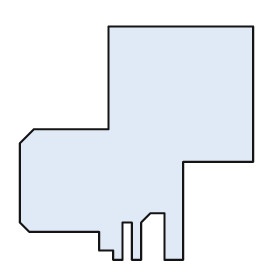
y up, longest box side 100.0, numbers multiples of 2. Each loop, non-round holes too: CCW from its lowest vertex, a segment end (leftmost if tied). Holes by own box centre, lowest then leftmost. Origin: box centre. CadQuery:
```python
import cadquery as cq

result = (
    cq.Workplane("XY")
    .moveTo(-10.0, -50.0)
    .lineTo(-6.0, -50.0)
    .lineTo(-6.0, -34.0)
    .lineTo(-2.0, -34.0)
    .lineTo(-2.0, -50.0)
    .lineTo(2.0, -50.0)
    .lineTo(2.0, -34.0)
    .lineTo(6.0, -30.0)
    .lineTo(12.0, -30.0)
    .lineTo(12.0, -50.0)
    .lineTo(20.0, -50.0)
    .lineTo(20.0, -8.0)
    .lineTo(50.0, -8.0)
    .lineTo(50.0, 50.0)
    .lineTo(-12.0, 50.0)
    .lineTo(-12.0, 6.0)
    .lineTo(-44.0, 6.0)
    .lineTo(-50.0, 0.0)
    .lineTo(-50.0, -34.0)
    .lineTo(-46.0, -38.0)
    .lineTo(-16.0, -38.0)
    .lineTo(-16.0, -46.0)
    .lineTo(-10.0, -46.0)
    .close()
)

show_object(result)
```